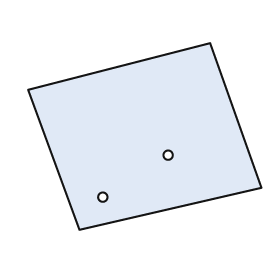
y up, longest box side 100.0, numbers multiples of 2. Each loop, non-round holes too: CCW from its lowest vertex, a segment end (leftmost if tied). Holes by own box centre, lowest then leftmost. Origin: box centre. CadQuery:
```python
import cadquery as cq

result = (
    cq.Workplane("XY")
    .moveTo(-28.0, -40.0)
    .lineTo(50.0, -22.0)
    .lineTo(28.0, 40.0)
    .lineTo(-50.0, 20.0)
    .close()
    .moveTo(-18.0, -26.0)
    .circle(2.0)
    .moveTo(10.0, -8.0)
    .circle(2.0)
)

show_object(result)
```